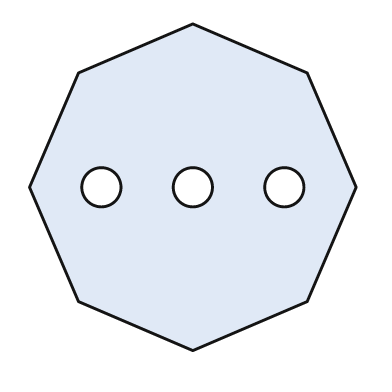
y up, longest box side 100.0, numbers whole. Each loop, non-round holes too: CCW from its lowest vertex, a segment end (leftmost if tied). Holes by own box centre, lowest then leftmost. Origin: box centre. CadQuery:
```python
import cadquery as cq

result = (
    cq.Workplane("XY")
    .moveTo(0.0, -50.0)
    .lineTo(35.0, -35.0)
    .lineTo(50.0, 0.0)
    .lineTo(35.0, 35.0)
    .lineTo(0.0, 50.0)
    .lineTo(-35.0, 35.0)
    .lineTo(-50.0, 0.0)
    .lineTo(-35.0, -35.0)
    .close()
    .moveTo(-28.0, 0.0)
    .circle(6.0)
    .moveTo(0.0, 0.0)
    .circle(6.0)
    .moveTo(28.0, 0.0)
    .circle(6.0)
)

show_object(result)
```